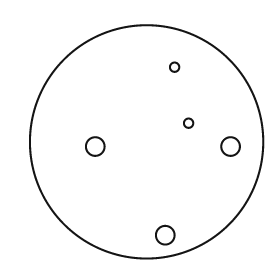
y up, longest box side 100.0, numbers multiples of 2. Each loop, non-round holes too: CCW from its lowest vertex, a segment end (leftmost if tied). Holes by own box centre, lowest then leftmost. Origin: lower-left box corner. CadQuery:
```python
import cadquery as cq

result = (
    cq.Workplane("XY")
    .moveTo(50.0, 50.0)
    .circle(50.0)
    .moveTo(58.0, 10.0)
    .circle(4.0)
    .moveTo(28.0, 48.0)
    .circle(4.0)
    .moveTo(86.0, 48.0)
    .circle(4.0)
    .moveTo(68.0, 58.0)
    .circle(2.0)
    .moveTo(62.0, 82.0)
    .circle(2.0)
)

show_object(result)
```